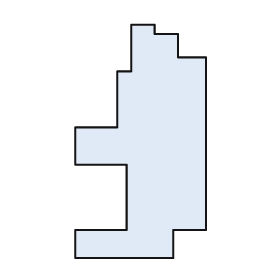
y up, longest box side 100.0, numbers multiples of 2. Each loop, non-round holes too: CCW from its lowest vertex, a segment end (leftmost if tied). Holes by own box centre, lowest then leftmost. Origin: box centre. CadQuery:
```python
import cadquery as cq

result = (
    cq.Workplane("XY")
    .moveTo(-28.0, -50.0)
    .lineTo(14.0, -50.0)
    .lineTo(14.0, -38.0)
    .lineTo(28.0, -38.0)
    .lineTo(28.0, 36.0)
    .lineTo(16.0, 36.0)
    .lineTo(16.0, 46.0)
    .lineTo(6.0, 46.0)
    .lineTo(6.0, 50.0)
    .lineTo(-4.0, 50.0)
    .lineTo(-4.0, 30.0)
    .lineTo(-10.0, 30.0)
    .lineTo(-10.0, 6.0)
    .lineTo(-28.0, 6.0)
    .lineTo(-28.0, -10.0)
    .lineTo(-6.0, -10.0)
    .lineTo(-6.0, -38.0)
    .lineTo(-28.0, -38.0)
    .close()
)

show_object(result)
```